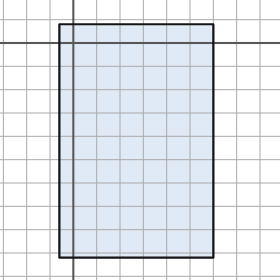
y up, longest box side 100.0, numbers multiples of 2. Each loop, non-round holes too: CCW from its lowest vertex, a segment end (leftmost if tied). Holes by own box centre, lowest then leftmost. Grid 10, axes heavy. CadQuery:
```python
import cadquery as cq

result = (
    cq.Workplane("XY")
    .moveTo(-6.0, -92.0)
    .lineTo(60.0, -92.0)
    .lineTo(60.0, 8.0)
    .lineTo(-6.0, 8.0)
    .close()
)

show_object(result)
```